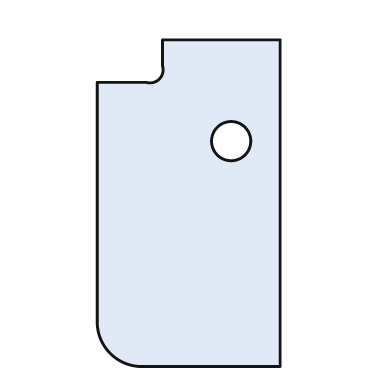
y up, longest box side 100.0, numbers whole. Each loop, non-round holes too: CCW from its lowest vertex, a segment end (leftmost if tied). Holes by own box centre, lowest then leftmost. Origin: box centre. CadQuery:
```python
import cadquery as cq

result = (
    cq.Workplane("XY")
    .moveTo(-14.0, -50.0)
    .lineTo(28.0, -50.0)
    .lineTo(28.0, 50.0)
    .lineTo(-8.0, 50.0)
    .lineTo(-8.0, 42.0)
    .threePointArc((-9.0, 38.0), (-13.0, 37.0))
    .lineTo(-28.0, 37.0)
    .lineTo(-28.0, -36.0)
    .threePointArc((-24.0, -46.0), (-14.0, -50.0))
    .close()
    .moveTo(13.0, 19.0)
    .circle(6.0)
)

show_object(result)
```